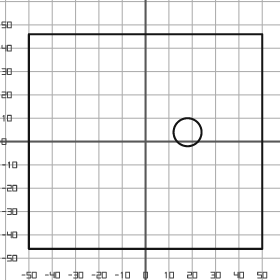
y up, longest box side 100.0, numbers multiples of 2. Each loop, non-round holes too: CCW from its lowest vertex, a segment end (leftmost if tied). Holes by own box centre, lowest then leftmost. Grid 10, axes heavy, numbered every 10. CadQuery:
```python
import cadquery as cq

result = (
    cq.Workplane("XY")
    .moveTo(-50.0, -46.0)
    .lineTo(50.0, -46.0)
    .lineTo(50.0, 46.0)
    .lineTo(-50.0, 46.0)
    .close()
    .moveTo(18.0, 4.0)
    .circle(6.0)
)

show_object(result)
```